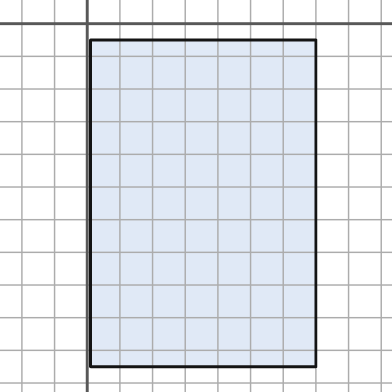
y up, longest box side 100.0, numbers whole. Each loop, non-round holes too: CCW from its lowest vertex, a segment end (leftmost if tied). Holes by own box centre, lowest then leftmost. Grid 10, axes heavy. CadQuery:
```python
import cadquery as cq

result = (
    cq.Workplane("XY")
    .moveTo(1.0, -105.0)
    .lineTo(70.0, -105.0)
    .lineTo(70.0, -5.0)
    .lineTo(1.0, -5.0)
    .close()
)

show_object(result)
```